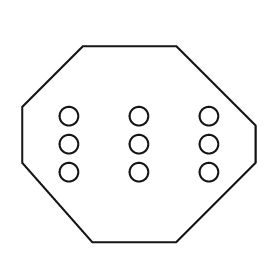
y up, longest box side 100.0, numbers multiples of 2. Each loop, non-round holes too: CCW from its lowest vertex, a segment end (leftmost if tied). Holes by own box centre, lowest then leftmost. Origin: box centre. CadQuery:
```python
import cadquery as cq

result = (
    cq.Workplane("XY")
    .moveTo(-20.0, -42.0)
    .lineTo(16.0, -42.0)
    .lineTo(50.0, -8.0)
    .lineTo(50.0, 8.0)
    .lineTo(16.0, 42.0)
    .lineTo(-24.0, 42.0)
    .lineTo(-50.0, 16.0)
    .lineTo(-50.0, -8.0)
    .close()
    .moveTo(-30.0, -12.0)
    .circle(4.0)
    .moveTo(0.0, -12.0)
    .circle(4.0)
    .moveTo(30.0, -12.0)
    .circle(4.0)
    .moveTo(-30.0, 0.0)
    .circle(4.0)
    .moveTo(0.0, 0.0)
    .circle(4.0)
    .moveTo(30.0, 0.0)
    .circle(4.0)
    .moveTo(-30.0, 12.0)
    .circle(4.0)
    .moveTo(0.0, 12.0)
    .circle(4.0)
    .moveTo(30.0, 12.0)
    .circle(4.0)
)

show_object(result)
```